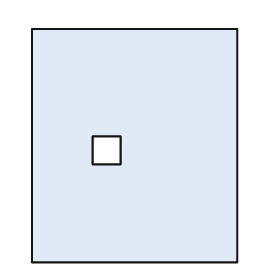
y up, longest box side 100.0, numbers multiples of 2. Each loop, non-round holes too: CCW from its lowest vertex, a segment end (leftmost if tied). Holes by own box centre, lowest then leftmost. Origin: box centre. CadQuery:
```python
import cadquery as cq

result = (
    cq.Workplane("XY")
    .moveTo(-44.0, -50.0)
    .lineTo(44.0, -50.0)
    .lineTo(44.0, 50.0)
    .lineTo(-44.0, 50.0)
    .close()
    .moveTo(-18.0, -8.0)
    .lineTo(-6.0, -8.0)
    .lineTo(-6.0, 4.0)
    .lineTo(-18.0, 4.0)
    .close()
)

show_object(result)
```